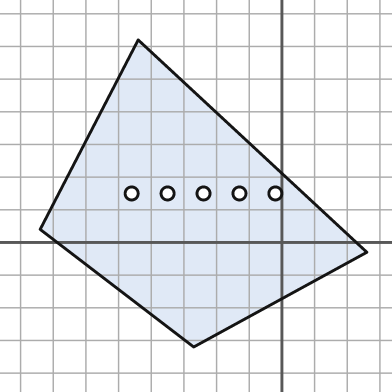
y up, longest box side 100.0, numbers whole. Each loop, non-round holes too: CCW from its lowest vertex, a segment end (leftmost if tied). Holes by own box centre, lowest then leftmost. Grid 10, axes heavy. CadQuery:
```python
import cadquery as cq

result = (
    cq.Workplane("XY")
    .moveTo(-27.0, -32.0)
    .lineTo(26.0, -3.0)
    .lineTo(-44.0, 62.0)
    .lineTo(-74.0, 4.0)
    .close()
    .moveTo(-46.0, 15.0)
    .circle(2.0)
    .moveTo(-35.0, 15.0)
    .circle(2.0)
    .moveTo(-24.0, 15.0)
    .circle(2.0)
    .moveTo(-13.0, 15.0)
    .circle(2.0)
    .moveTo(-2.0, 15.0)
    .circle(2.0)
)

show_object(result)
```